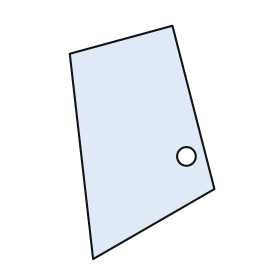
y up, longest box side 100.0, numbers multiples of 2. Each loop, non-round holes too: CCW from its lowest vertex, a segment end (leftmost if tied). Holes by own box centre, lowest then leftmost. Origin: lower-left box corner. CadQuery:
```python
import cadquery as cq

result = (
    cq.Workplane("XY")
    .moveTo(10.0, 0.0)
    .lineTo(62.0, 30.0)
    .lineTo(44.0, 100.0)
    .lineTo(0.0, 88.0)
    .close()
    .moveTo(50.0, 44.0)
    .circle(4.0)
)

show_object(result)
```